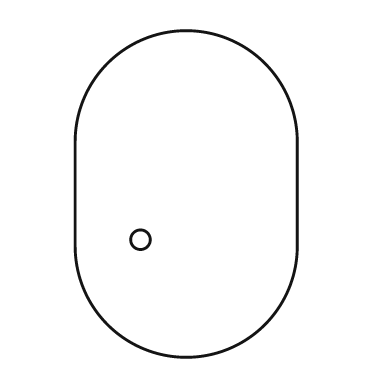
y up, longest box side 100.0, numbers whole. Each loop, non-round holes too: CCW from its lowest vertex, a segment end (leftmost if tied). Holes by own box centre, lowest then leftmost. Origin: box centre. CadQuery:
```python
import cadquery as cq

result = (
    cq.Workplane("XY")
    .moveTo(-34.0, -16.0)
    .threePointArc((0.0, -50.0), (34.0, -16.0))
    .lineTo(34.0, 16.0)
    .threePointArc((0.0, 50.0), (-34.0, 16.0))
    .close()
    .moveTo(-14.0, -14.0)
    .circle(3.0)
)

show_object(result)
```